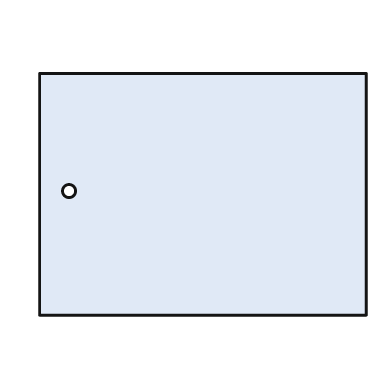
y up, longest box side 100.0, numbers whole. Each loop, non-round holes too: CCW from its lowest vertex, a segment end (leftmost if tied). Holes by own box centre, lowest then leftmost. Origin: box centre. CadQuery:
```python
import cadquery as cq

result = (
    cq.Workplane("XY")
    .moveTo(-50.0, -37.0)
    .lineTo(50.0, -37.0)
    .lineTo(50.0, 37.0)
    .lineTo(-50.0, 37.0)
    .close()
    .moveTo(-41.0, 1.0)
    .circle(2.0)
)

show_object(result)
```